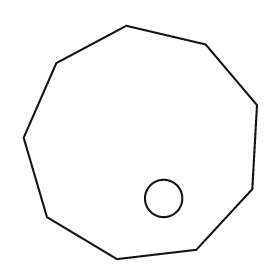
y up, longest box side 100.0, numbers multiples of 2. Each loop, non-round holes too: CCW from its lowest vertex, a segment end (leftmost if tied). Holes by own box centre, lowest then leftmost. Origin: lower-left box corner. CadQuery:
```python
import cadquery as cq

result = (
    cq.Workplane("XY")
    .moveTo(40.0, 0.0)
    .lineTo(74.0, 4.0)
    .lineTo(98.0, 30.0)
    .lineTo(100.0, 66.0)
    .lineTo(78.0, 92.0)
    .lineTo(44.0, 100.0)
    .lineTo(14.0, 84.0)
    .lineTo(0.0, 52.0)
    .lineTo(10.0, 18.0)
    .close()
    .moveTo(60.0, 26.0)
    .circle(8.0)
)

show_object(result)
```